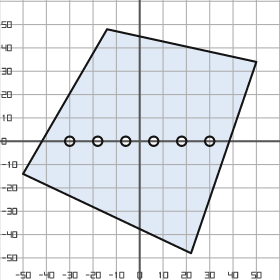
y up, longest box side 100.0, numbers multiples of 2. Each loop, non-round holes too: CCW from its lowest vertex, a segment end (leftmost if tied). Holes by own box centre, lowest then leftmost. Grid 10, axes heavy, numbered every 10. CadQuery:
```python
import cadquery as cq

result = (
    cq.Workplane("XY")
    .moveTo(22.0, -48.0)
    .lineTo(50.0, 34.0)
    .lineTo(-14.0, 48.0)
    .lineTo(-50.0, -14.0)
    .close()
    .moveTo(-30.0, 0.0)
    .circle(2.0)
    .moveTo(-18.0, 0.0)
    .circle(2.0)
    .moveTo(-6.0, 0.0)
    .circle(2.0)
    .moveTo(6.0, 0.0)
    .circle(2.0)
    .moveTo(18.0, 0.0)
    .circle(2.0)
    .moveTo(30.0, 0.0)
    .circle(2.0)
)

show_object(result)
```